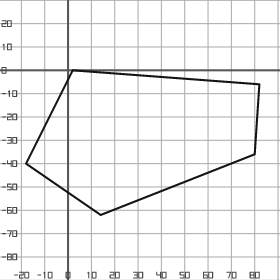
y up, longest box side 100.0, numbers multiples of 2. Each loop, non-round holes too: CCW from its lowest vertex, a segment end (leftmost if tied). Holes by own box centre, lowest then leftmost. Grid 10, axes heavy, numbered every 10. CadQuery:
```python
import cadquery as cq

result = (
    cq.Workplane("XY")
    .moveTo(14.0, -62.0)
    .lineTo(80.0, -36.0)
    .lineTo(82.0, -6.0)
    .lineTo(2.0, 0.0)
    .lineTo(-18.0, -40.0)
    .close()
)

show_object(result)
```